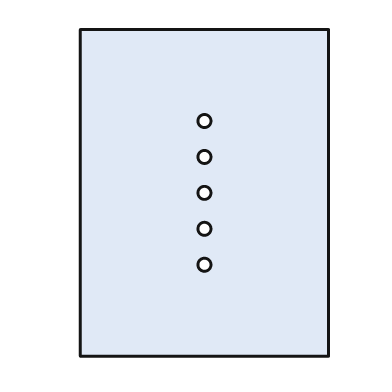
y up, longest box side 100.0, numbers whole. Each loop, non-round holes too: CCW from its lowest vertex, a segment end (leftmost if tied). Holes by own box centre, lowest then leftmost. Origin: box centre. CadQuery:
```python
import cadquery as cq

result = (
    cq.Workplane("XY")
    .moveTo(-38.0, -50.0)
    .lineTo(38.0, -50.0)
    .lineTo(38.0, 50.0)
    .lineTo(-38.0, 50.0)
    .close()
    .moveTo(0.0, -22.0)
    .circle(2.0)
    .moveTo(0.0, -11.0)
    .circle(2.0)
    .moveTo(0.0, 0.0)
    .circle(2.0)
    .moveTo(0.0, 11.0)
    .circle(2.0)
    .moveTo(0.0, 22.0)
    .circle(2.0)
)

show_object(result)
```